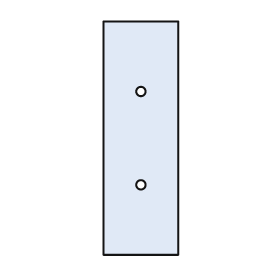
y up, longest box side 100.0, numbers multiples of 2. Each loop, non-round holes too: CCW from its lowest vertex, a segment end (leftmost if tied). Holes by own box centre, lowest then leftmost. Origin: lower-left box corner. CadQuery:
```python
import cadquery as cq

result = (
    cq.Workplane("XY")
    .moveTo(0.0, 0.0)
    .lineTo(32.0, 0.0)
    .lineTo(32.0, 100.0)
    .lineTo(0.0, 100.0)
    .close()
    .moveTo(16.0, 30.0)
    .circle(2.0)
    .moveTo(16.0, 70.0)
    .circle(2.0)
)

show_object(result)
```